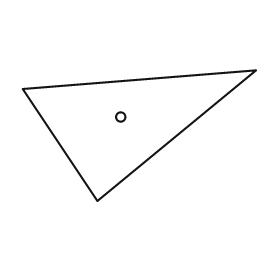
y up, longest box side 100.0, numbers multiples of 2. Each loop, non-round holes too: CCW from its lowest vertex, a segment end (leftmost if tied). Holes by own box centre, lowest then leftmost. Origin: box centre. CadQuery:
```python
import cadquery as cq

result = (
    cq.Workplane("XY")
    .moveTo(-18.0, -28.0)
    .lineTo(50.0, 28.0)
    .lineTo(-50.0, 20.0)
    .close()
    .moveTo(-8.0, 8.0)
    .circle(2.0)
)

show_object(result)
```